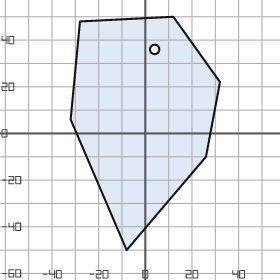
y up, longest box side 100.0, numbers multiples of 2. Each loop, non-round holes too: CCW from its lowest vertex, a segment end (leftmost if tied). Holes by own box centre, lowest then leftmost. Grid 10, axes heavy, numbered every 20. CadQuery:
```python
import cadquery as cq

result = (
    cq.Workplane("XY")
    .moveTo(-8.0, -50.0)
    .lineTo(26.0, -10.0)
    .lineTo(32.0, 22.0)
    .lineTo(12.0, 50.0)
    .lineTo(-28.0, 48.0)
    .lineTo(-32.0, 6.0)
    .close()
    .moveTo(4.0, 36.0)
    .circle(2.0)
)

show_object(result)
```